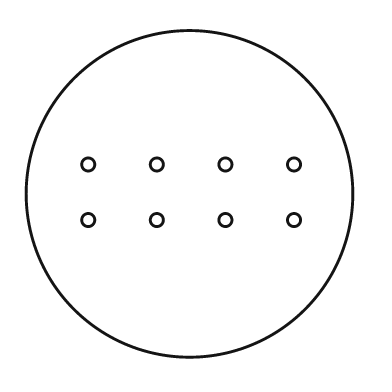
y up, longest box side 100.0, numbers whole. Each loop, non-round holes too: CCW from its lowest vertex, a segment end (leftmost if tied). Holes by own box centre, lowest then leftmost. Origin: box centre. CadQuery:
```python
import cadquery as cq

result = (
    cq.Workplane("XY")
    .moveTo(0.0, 0.0)
    .circle(50.0)
    .moveTo(-31.0, -8.0)
    .circle(2.0)
    .moveTo(-10.0, -8.0)
    .circle(2.0)
    .moveTo(11.0, -8.0)
    .circle(2.0)
    .moveTo(32.0, -8.0)
    .circle(2.0)
    .moveTo(-31.0, 9.0)
    .circle(2.0)
    .moveTo(-10.0, 9.0)
    .circle(2.0)
    .moveTo(11.0, 9.0)
    .circle(2.0)
    .moveTo(32.0, 9.0)
    .circle(2.0)
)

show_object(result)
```